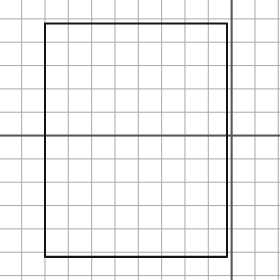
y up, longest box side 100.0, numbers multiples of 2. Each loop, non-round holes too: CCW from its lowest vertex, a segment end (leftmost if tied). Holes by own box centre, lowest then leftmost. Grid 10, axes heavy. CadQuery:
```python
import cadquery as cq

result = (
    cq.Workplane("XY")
    .moveTo(-80.0, -52.0)
    .lineTo(-2.0, -52.0)
    .lineTo(-2.0, 48.0)
    .lineTo(-80.0, 48.0)
    .close()
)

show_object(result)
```